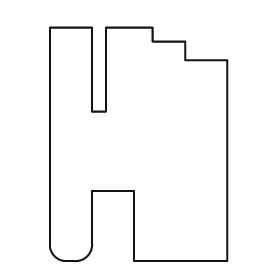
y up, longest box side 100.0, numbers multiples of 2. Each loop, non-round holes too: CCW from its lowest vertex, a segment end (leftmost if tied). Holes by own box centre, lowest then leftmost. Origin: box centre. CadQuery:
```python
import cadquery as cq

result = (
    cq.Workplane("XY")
    .moveTo(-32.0, -50.0)
    .lineTo(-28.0, -50.0)
    .threePointArc((-22.0, -48.0), (-20.0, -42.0))
    .lineTo(-20.0, -20.0)
    .lineTo(-2.0, -20.0)
    .lineTo(-2.0, -50.0)
    .lineTo(38.0, -50.0)
    .lineTo(38.0, 36.0)
    .lineTo(20.0, 36.0)
    .lineTo(20.0, 44.0)
    .lineTo(6.0, 44.0)
    .lineTo(6.0, 50.0)
    .lineTo(-14.0, 50.0)
    .lineTo(-14.0, 14.0)
    .lineTo(-20.0, 14.0)
    .lineTo(-20.0, 50.0)
    .lineTo(-38.0, 50.0)
    .lineTo(-38.0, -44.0)
    .threePointArc((-36.0, -48.0), (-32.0, -50.0))
    .close()
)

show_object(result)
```